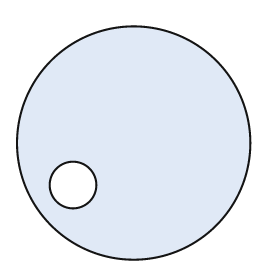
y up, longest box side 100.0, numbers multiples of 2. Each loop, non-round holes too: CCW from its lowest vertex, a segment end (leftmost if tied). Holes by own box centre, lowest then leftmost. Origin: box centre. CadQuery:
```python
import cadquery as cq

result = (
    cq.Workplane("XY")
    .moveTo(0.0, 0.0)
    .circle(50.0)
    .moveTo(-26.0, -18.0)
    .circle(10.0)
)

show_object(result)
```